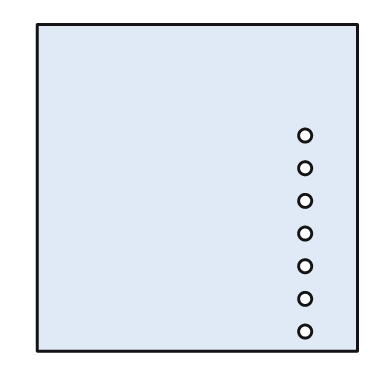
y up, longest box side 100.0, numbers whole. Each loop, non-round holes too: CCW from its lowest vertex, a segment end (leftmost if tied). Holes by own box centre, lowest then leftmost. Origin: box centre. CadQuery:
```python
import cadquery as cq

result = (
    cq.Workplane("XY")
    .moveTo(-49.0, -50.0)
    .lineTo(49.0, -50.0)
    .lineTo(49.0, 50.0)
    .lineTo(-49.0, 50.0)
    .close()
    .moveTo(33.0, -44.0)
    .circle(2.0)
    .moveTo(33.0, -34.0)
    .circle(2.0)
    .moveTo(33.0, -24.0)
    .circle(2.0)
    .moveTo(33.0, -14.0)
    .circle(2.0)
    .moveTo(33.0, -4.0)
    .circle(2.0)
    .moveTo(33.0, 6.0)
    .circle(2.0)
    .moveTo(33.0, 16.0)
    .circle(2.0)
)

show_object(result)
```